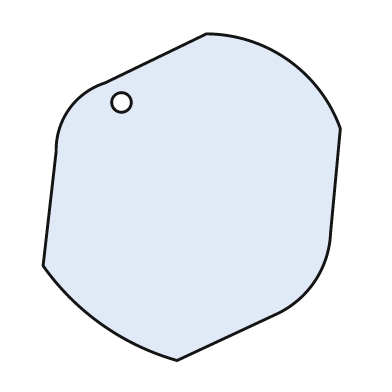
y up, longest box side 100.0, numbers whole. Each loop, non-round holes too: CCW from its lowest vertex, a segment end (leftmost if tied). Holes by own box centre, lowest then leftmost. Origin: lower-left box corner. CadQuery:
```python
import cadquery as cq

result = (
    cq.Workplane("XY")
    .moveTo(41.0, 0.0)
    .lineTo(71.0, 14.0)
    .threePointArc((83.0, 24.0), (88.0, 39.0))
    .lineTo(91.0, 71.0)
    .threePointArc((75.0, 92.0), (50.0, 100.0))
    .lineTo(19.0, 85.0)
    .threePointArc((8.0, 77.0), (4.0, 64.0))
    .lineTo(0.0, 29.0)
    .threePointArc((18.0, 11.0), (41.0, 0.0))
    .close()
    .moveTo(24.0, 79.0)
    .circle(3.0)
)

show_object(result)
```